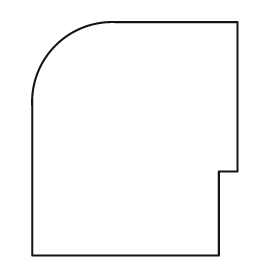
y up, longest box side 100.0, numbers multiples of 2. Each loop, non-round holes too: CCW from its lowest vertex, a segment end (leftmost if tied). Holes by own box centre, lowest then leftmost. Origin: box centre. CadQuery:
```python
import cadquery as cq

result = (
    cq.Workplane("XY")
    .moveTo(-44.0, -50.0)
    .lineTo(36.0, -50.0)
    .lineTo(36.0, -14.0)
    .lineTo(44.0, -14.0)
    .lineTo(44.0, 50.0)
    .lineTo(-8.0, 50.0)
    .threePointArc((-34.0, 40.0), (-44.0, 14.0))
    .close()
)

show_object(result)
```